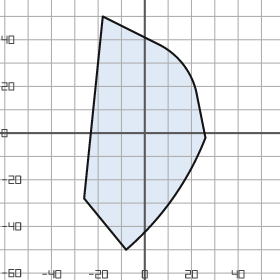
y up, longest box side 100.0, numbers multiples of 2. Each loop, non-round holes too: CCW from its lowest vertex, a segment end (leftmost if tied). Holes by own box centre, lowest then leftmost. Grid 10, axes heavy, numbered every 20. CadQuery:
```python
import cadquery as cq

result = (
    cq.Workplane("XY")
    .moveTo(-8.0, -50.0)
    .threePointArc((12.0, -28.0), (26.0, -2.0))
    .lineTo(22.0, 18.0)
    .threePointArc((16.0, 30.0), (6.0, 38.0))
    .lineTo(-18.0, 50.0)
    .lineTo(-26.0, -28.0)
    .close()
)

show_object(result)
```